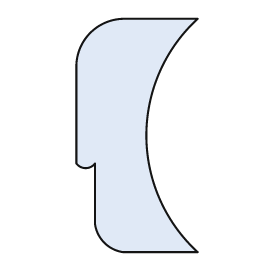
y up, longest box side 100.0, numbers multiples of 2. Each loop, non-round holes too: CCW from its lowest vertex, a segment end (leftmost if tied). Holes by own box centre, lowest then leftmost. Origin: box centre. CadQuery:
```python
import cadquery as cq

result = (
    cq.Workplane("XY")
    .moveTo(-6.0, -50.0)
    .lineTo(26.0, -50.0)
    .threePointArc((4.0, 0.0), (26.0, 50.0))
    .lineTo(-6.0, 50.0)
    .threePointArc((-20.0, 44.0), (-26.0, 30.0))
    .lineTo(-26.0, -12.0)
    .threePointArc((-22.0, -14.0), (-18.0, -12.0))
    .lineTo(-18.0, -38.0)
    .threePointArc((-14.0, -46.0), (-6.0, -50.0))
    .close()
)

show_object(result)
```